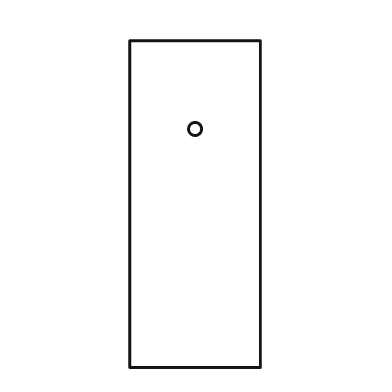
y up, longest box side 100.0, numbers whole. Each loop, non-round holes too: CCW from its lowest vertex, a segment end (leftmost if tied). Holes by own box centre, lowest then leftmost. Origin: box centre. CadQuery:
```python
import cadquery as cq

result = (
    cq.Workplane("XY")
    .moveTo(-20.0, -50.0)
    .lineTo(20.0, -50.0)
    .lineTo(20.0, 50.0)
    .lineTo(-20.0, 50.0)
    .close()
    .moveTo(0.0, 23.0)
    .circle(2.0)
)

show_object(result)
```